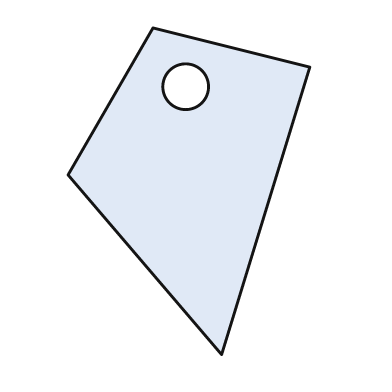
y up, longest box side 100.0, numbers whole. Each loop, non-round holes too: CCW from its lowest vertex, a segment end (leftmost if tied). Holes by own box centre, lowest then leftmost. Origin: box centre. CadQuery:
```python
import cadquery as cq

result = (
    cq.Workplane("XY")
    .moveTo(10.0, -50.0)
    .lineTo(37.0, 38.0)
    .lineTo(-11.0, 50.0)
    .lineTo(-37.0, 5.0)
    .close()
    .moveTo(-1.0, 32.0)
    .circle(7.0)
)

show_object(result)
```